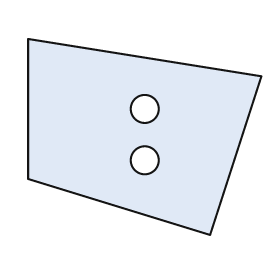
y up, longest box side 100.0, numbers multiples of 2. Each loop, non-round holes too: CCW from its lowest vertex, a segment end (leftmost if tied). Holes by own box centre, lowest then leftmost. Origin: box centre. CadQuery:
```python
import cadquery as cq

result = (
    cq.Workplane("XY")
    .moveTo(28.0, -42.0)
    .lineTo(50.0, 26.0)
    .lineTo(-50.0, 42.0)
    .lineTo(-50.0, -18.0)
    .close()
    .moveTo(0.0, -10.0)
    .circle(6.0)
    .moveTo(0.0, 12.0)
    .circle(6.0)
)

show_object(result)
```